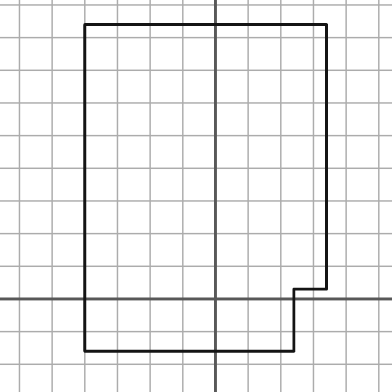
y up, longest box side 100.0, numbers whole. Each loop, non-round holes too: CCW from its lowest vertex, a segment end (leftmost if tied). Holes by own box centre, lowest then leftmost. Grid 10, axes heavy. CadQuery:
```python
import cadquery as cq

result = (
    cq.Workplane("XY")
    .moveTo(-40.0, -16.0)
    .lineTo(24.0, -16.0)
    .lineTo(24.0, 3.0)
    .lineTo(34.0, 3.0)
    .lineTo(34.0, 84.0)
    .lineTo(-40.0, 84.0)
    .close()
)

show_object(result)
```